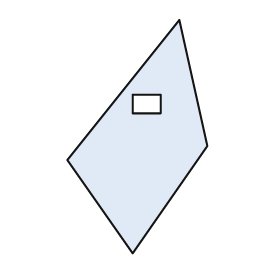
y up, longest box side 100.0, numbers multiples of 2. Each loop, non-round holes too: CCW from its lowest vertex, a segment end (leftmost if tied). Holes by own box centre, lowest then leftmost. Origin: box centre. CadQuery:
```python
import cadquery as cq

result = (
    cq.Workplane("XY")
    .moveTo(-2.0, -50.0)
    .lineTo(30.0, -4.0)
    .lineTo(18.0, 50.0)
    .lineTo(-30.0, -10.0)
    .close()
    .moveTo(-2.0, 10.0)
    .lineTo(10.0, 10.0)
    .lineTo(10.0, 18.0)
    .lineTo(-2.0, 18.0)
    .close()
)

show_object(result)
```